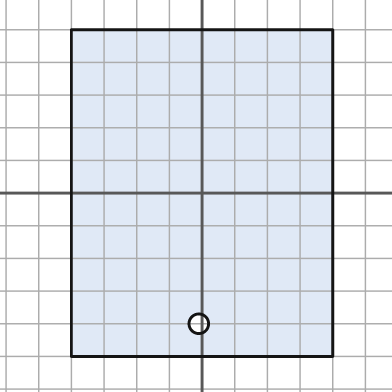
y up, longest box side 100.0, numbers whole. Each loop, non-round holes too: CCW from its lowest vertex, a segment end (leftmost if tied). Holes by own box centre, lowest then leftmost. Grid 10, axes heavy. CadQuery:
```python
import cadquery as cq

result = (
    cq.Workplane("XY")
    .moveTo(-40.0, -50.0)
    .lineTo(40.0, -50.0)
    .lineTo(40.0, 50.0)
    .lineTo(-40.0, 50.0)
    .close()
    .moveTo(-1.0, -40.0)
    .circle(3.0)
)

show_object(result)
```